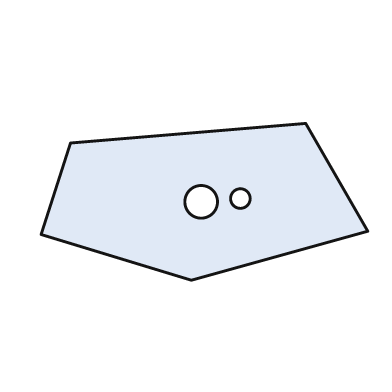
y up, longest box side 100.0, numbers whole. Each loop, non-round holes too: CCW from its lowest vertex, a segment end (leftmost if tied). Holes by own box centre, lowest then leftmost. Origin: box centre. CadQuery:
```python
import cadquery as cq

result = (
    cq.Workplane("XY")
    .moveTo(-4.0, -24.0)
    .lineTo(50.0, -9.0)
    .lineTo(31.0, 24.0)
    .lineTo(-41.0, 18.0)
    .lineTo(-50.0, -10.0)
    .close()
    .moveTo(-1.0, 0.0)
    .circle(5.0)
    .moveTo(11.0, 1.0)
    .circle(3.0)
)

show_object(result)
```